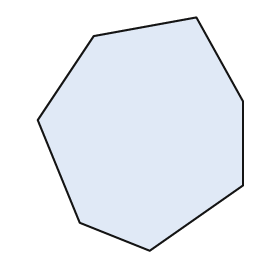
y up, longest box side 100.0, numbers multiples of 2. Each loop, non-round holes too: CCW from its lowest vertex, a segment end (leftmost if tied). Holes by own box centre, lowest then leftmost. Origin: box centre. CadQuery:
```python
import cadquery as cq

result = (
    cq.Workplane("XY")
    .moveTo(4.0, -50.0)
    .lineTo(44.0, -22.0)
    .lineTo(44.0, 14.0)
    .lineTo(24.0, 50.0)
    .lineTo(-20.0, 42.0)
    .lineTo(-44.0, 6.0)
    .lineTo(-26.0, -38.0)
    .close()
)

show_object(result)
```